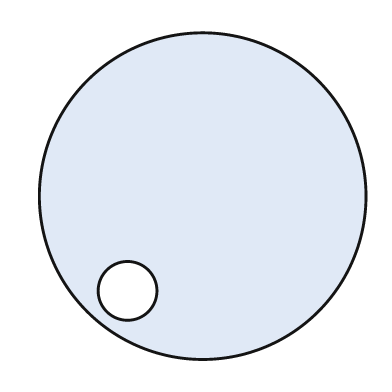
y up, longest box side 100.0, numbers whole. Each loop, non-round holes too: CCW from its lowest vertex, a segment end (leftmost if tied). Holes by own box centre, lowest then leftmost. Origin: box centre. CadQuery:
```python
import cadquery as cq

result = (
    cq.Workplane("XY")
    .moveTo(0.0, 0.0)
    .circle(50.0)
    .moveTo(-23.0, -29.0)
    .circle(9.0)
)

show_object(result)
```